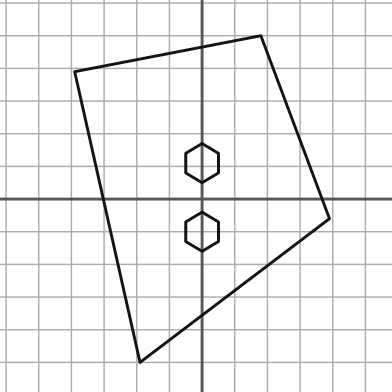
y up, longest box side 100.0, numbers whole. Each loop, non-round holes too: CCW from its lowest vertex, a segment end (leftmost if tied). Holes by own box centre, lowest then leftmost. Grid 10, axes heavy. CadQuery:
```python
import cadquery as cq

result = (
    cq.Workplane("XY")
    .moveTo(-19.0, -50.0)
    .lineTo(39.0, -6.0)
    .lineTo(18.0, 50.0)
    .lineTo(-39.0, 39.0)
    .close()
    .moveTo(0.0, -16.0)
    .lineTo(5.0, -13.0)
    .lineTo(5.0, -7.0)
    .lineTo(0.0, -4.0)
    .lineTo(-5.0, -7.0)
    .lineTo(-5.0, -13.0)
    .close()
    .moveTo(0.0, 5.0)
    .lineTo(5.0, 8.0)
    .lineTo(5.0, 14.0)
    .lineTo(0.0, 17.0)
    .lineTo(-5.0, 14.0)
    .lineTo(-5.0, 8.0)
    .close()
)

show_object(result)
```